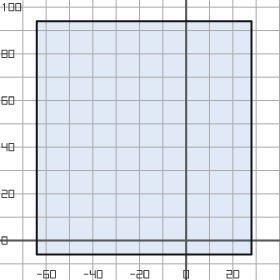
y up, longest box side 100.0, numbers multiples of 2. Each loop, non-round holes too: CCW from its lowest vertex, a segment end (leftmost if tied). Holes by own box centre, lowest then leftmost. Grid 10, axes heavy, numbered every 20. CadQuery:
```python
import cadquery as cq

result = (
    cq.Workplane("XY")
    .moveTo(-64.0, -6.0)
    .lineTo(28.0, -6.0)
    .lineTo(28.0, 94.0)
    .lineTo(-64.0, 94.0)
    .close()
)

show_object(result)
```